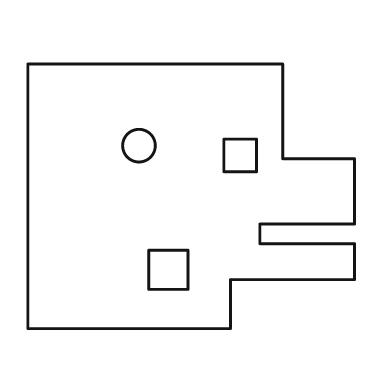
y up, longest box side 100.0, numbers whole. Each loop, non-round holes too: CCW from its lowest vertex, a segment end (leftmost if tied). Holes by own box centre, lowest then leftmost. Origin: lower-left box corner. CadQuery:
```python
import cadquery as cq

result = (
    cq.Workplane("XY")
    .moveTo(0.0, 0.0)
    .lineTo(62.0, 0.0)
    .lineTo(62.0, 15.0)
    .lineTo(100.0, 15.0)
    .lineTo(100.0, 26.0)
    .lineTo(71.0, 26.0)
    .lineTo(71.0, 32.0)
    .lineTo(100.0, 32.0)
    .lineTo(100.0, 52.0)
    .lineTo(78.0, 52.0)
    .lineTo(78.0, 81.0)
    .lineTo(0.0, 81.0)
    .close()
    .moveTo(37.0, 12.0)
    .lineTo(49.0, 12.0)
    .lineTo(49.0, 24.0)
    .lineTo(37.0, 24.0)
    .close()
    .moveTo(60.0, 48.0)
    .lineTo(70.0, 48.0)
    .lineTo(70.0, 58.0)
    .lineTo(60.0, 58.0)
    .close()
    .moveTo(34.0, 56.0)
    .circle(5.0)
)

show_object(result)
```